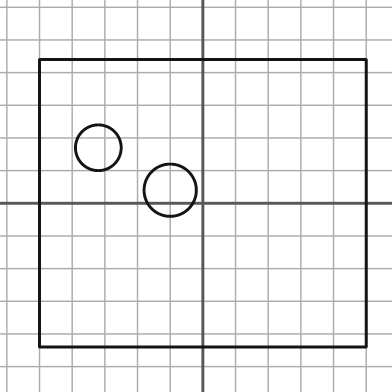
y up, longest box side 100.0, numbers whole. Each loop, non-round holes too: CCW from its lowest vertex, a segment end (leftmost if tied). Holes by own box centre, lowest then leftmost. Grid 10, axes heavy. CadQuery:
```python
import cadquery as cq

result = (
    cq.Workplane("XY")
    .moveTo(-50.0, -44.0)
    .lineTo(50.0, -44.0)
    .lineTo(50.0, 44.0)
    .lineTo(-50.0, 44.0)
    .close()
    .moveTo(-10.0, 4.0)
    .circle(8.0)
    .moveTo(-32.0, 17.0)
    .circle(7.0)
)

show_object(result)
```